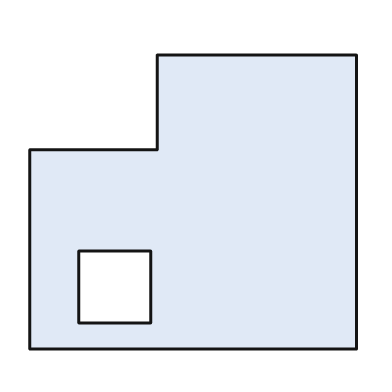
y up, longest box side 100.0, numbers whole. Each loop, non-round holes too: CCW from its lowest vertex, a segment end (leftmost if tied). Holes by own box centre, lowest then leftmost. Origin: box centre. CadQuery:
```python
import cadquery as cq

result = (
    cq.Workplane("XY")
    .moveTo(-50.0, -45.0)
    .lineTo(50.0, -45.0)
    .lineTo(50.0, 45.0)
    .lineTo(-11.0, 45.0)
    .lineTo(-11.0, 16.0)
    .lineTo(-50.0, 16.0)
    .close()
    .moveTo(-35.0, -37.0)
    .lineTo(-13.0, -37.0)
    .lineTo(-13.0, -15.0)
    .lineTo(-35.0, -15.0)
    .close()
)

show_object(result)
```